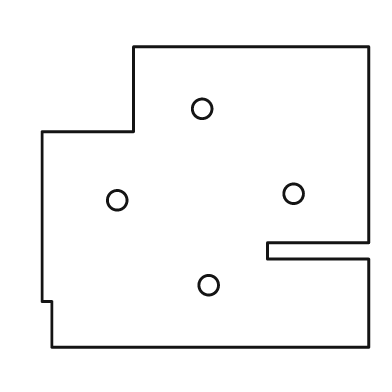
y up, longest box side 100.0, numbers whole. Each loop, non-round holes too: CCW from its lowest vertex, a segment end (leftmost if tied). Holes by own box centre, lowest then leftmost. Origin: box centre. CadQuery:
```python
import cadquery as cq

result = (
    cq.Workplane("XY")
    .moveTo(-47.0, -46.0)
    .lineTo(50.0, -46.0)
    .lineTo(50.0, -19.0)
    .lineTo(19.0, -19.0)
    .lineTo(19.0, -14.0)
    .lineTo(50.0, -14.0)
    .lineTo(50.0, 46.0)
    .lineTo(-22.0, 46.0)
    .lineTo(-22.0, 20.0)
    .lineTo(-50.0, 20.0)
    .lineTo(-50.0, -32.0)
    .lineTo(-47.0, -32.0)
    .close()
    .moveTo(1.0, -27.0)
    .circle(3.0)
    .moveTo(-27.0, -1.0)
    .circle(3.0)
    .moveTo(27.0, 1.0)
    .circle(3.0)
    .moveTo(-1.0, 27.0)
    .circle(3.0)
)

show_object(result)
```